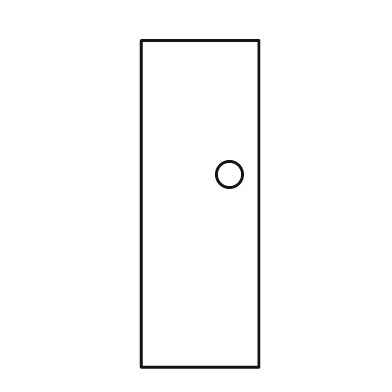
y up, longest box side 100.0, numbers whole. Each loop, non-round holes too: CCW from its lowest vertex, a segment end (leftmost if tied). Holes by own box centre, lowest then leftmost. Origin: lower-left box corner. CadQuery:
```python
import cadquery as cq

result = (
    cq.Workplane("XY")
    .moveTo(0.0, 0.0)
    .lineTo(36.0, 0.0)
    .lineTo(36.0, 100.0)
    .lineTo(0.0, 100.0)
    .close()
    .moveTo(27.0, 59.0)
    .circle(4.0)
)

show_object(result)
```